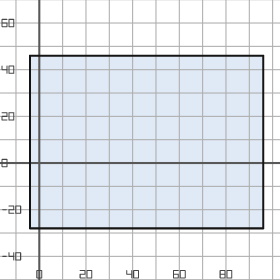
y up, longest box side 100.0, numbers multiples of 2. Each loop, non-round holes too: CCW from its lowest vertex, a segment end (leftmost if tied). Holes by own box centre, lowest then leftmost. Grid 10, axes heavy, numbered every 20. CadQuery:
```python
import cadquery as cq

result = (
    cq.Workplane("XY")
    .moveTo(-4.0, -28.0)
    .lineTo(96.0, -28.0)
    .lineTo(96.0, 46.0)
    .lineTo(-4.0, 46.0)
    .close()
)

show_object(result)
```